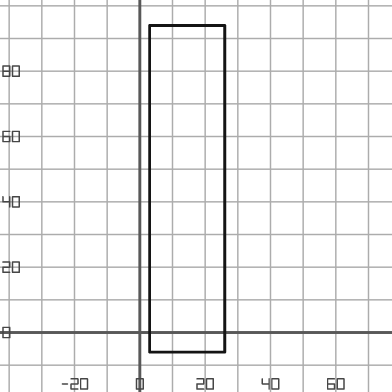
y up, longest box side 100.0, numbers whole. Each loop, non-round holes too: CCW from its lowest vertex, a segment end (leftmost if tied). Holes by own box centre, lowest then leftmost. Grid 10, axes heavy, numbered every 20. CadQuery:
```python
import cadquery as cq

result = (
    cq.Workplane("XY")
    .moveTo(3.0, -6.0)
    .lineTo(26.0, -6.0)
    .lineTo(26.0, 94.0)
    .lineTo(3.0, 94.0)
    .close()
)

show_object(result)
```